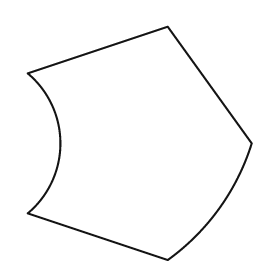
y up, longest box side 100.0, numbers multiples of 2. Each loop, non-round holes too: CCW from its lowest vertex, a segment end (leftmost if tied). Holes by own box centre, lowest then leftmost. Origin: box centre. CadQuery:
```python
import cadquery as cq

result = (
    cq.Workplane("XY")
    .moveTo(12.0, -50.0)
    .threePointArc((34.0, -28.0), (48.0, 0.0))
    .lineTo(12.0, 50.0)
    .lineTo(-48.0, 30.0)
    .threePointArc((-34.0, 0.0), (-48.0, -30.0))
    .close()
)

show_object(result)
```